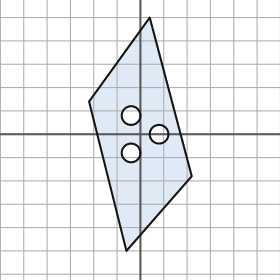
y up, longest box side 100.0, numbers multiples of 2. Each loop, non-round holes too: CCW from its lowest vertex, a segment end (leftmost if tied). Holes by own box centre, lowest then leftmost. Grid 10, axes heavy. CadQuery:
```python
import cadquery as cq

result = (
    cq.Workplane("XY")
    .moveTo(-6.0, -50.0)
    .lineTo(22.0, -18.0)
    .lineTo(4.0, 50.0)
    .lineTo(-22.0, 14.0)
    .close()
    .moveTo(-4.0, -8.0)
    .circle(4.0)
    .moveTo(8.0, 0.0)
    .circle(4.0)
    .moveTo(-4.0, 8.0)
    .circle(4.0)
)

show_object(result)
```